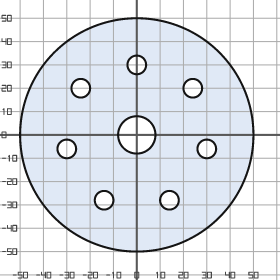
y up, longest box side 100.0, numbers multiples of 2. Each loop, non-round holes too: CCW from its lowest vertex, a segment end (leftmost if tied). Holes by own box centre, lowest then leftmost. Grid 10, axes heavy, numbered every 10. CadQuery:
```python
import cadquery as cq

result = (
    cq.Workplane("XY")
    .moveTo(0.0, 0.0)
    .circle(50.0)
    .moveTo(-14.0, -28.0)
    .circle(4.0)
    .moveTo(14.0, -28.0)
    .circle(4.0)
    .moveTo(-30.0, -6.0)
    .circle(4.0)
    .moveTo(30.0, -6.0)
    .circle(4.0)
    .moveTo(0.0, 0.0)
    .circle(8.0)
    .moveTo(-24.0, 20.0)
    .circle(4.0)
    .moveTo(24.0, 20.0)
    .circle(4.0)
    .moveTo(0.0, 30.0)
    .circle(4.0)
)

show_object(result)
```